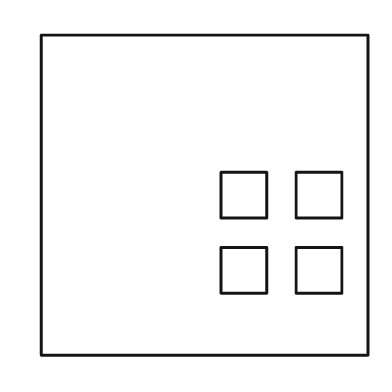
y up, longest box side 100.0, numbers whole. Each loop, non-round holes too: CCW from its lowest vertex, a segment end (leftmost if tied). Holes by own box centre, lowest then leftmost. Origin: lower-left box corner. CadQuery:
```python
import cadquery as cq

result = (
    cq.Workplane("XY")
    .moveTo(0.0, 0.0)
    .lineTo(100.0, 0.0)
    .lineTo(100.0, 98.0)
    .lineTo(0.0, 98.0)
    .close()
    .moveTo(55.0, 19.0)
    .lineTo(69.0, 19.0)
    .lineTo(69.0, 33.0)
    .lineTo(55.0, 33.0)
    .close()
    .moveTo(78.0, 19.0)
    .lineTo(92.0, 19.0)
    .lineTo(92.0, 33.0)
    .lineTo(78.0, 33.0)
    .close()
    .moveTo(55.0, 42.0)
    .lineTo(69.0, 42.0)
    .lineTo(69.0, 56.0)
    .lineTo(55.0, 56.0)
    .close()
    .moveTo(78.0, 42.0)
    .lineTo(92.0, 42.0)
    .lineTo(92.0, 56.0)
    .lineTo(78.0, 56.0)
    .close()
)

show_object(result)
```